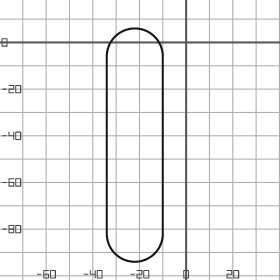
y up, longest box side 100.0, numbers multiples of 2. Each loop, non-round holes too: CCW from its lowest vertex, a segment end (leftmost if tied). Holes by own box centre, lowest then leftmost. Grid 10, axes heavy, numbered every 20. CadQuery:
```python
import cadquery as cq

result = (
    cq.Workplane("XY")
    .moveTo(-34.0, -82.0)
    .threePointArc((-22.0, -94.0), (-10.0, -82.0))
    .lineTo(-10.0, -6.0)
    .threePointArc((-22.0, 6.0), (-34.0, -6.0))
    .close()
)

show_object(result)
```